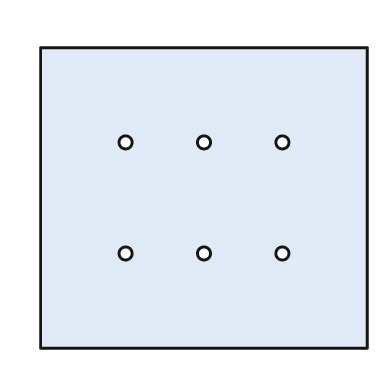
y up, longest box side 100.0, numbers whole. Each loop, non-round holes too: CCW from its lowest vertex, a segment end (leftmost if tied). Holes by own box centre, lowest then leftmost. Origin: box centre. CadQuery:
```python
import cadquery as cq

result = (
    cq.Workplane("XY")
    .moveTo(-50.0, -46.0)
    .lineTo(50.0, -46.0)
    .lineTo(50.0, 46.0)
    .lineTo(-50.0, 46.0)
    .close()
    .moveTo(-24.0, -17.0)
    .circle(2.0)
    .moveTo(0.0, -17.0)
    .circle(2.0)
    .moveTo(24.0, -17.0)
    .circle(2.0)
    .moveTo(-24.0, 17.0)
    .circle(2.0)
    .moveTo(0.0, 17.0)
    .circle(2.0)
    .moveTo(24.0, 17.0)
    .circle(2.0)
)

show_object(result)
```